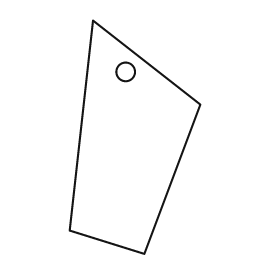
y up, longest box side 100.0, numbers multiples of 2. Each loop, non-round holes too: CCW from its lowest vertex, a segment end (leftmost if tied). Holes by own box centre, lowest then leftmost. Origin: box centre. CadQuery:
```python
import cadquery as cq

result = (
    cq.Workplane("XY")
    .moveTo(4.0, -50.0)
    .lineTo(28.0, 14.0)
    .lineTo(-18.0, 50.0)
    .lineTo(-28.0, -40.0)
    .close()
    .moveTo(-4.0, 28.0)
    .circle(4.0)
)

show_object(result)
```